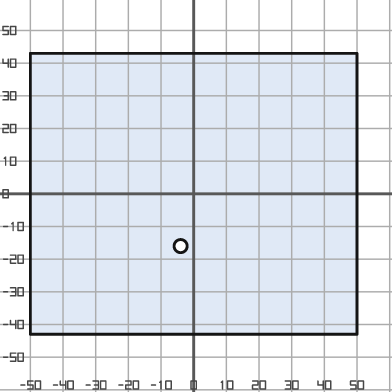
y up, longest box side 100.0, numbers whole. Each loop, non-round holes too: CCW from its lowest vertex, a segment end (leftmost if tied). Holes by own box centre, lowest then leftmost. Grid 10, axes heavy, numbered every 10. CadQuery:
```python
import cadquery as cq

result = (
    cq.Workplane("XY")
    .moveTo(-50.0, -43.0)
    .lineTo(50.0, -43.0)
    .lineTo(50.0, 43.0)
    .lineTo(-50.0, 43.0)
    .close()
    .moveTo(-4.0, -16.0)
    .circle(2.0)
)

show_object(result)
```